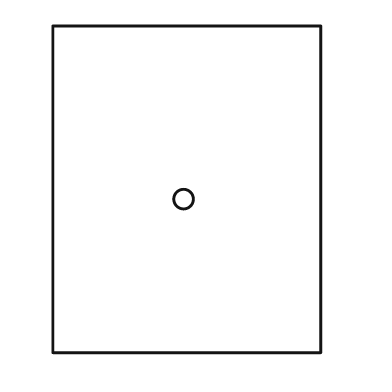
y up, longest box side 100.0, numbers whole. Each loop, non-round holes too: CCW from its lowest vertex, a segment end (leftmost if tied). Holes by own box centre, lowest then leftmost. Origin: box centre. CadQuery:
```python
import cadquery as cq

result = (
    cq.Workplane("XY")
    .moveTo(-41.0, -50.0)
    .lineTo(41.0, -50.0)
    .lineTo(41.0, 50.0)
    .lineTo(-41.0, 50.0)
    .close()
    .moveTo(-1.0, -3.0)
    .circle(3.0)
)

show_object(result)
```